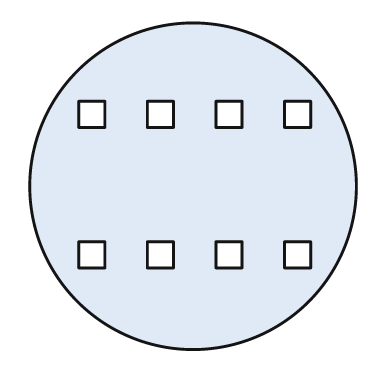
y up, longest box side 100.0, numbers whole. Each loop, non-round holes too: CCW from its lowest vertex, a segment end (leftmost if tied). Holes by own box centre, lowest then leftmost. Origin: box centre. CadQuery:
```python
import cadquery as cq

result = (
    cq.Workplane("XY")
    .moveTo(0.0, 0.0)
    .circle(50.0)
    .moveTo(-35.0, -25.0)
    .lineTo(-27.0, -25.0)
    .lineTo(-27.0, -17.0)
    .lineTo(-35.0, -17.0)
    .close()
    .moveTo(-14.0, -25.0)
    .lineTo(-6.0, -25.0)
    .lineTo(-6.0, -17.0)
    .lineTo(-14.0, -17.0)
    .close()
    .moveTo(7.0, -25.0)
    .lineTo(15.0, -25.0)
    .lineTo(15.0, -17.0)
    .lineTo(7.0, -17.0)
    .close()
    .moveTo(28.0, -25.0)
    .lineTo(36.0, -25.0)
    .lineTo(36.0, -17.0)
    .lineTo(28.0, -17.0)
    .close()
    .moveTo(-35.0, 18.0)
    .lineTo(-27.0, 18.0)
    .lineTo(-27.0, 26.0)
    .lineTo(-35.0, 26.0)
    .close()
    .moveTo(-14.0, 18.0)
    .lineTo(-6.0, 18.0)
    .lineTo(-6.0, 26.0)
    .lineTo(-14.0, 26.0)
    .close()
    .moveTo(7.0, 18.0)
    .lineTo(15.0, 18.0)
    .lineTo(15.0, 26.0)
    .lineTo(7.0, 26.0)
    .close()
    .moveTo(28.0, 18.0)
    .lineTo(36.0, 18.0)
    .lineTo(36.0, 26.0)
    .lineTo(28.0, 26.0)
    .close()
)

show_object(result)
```